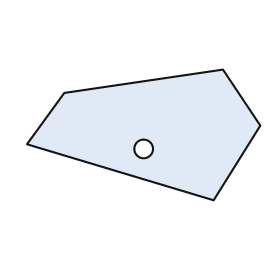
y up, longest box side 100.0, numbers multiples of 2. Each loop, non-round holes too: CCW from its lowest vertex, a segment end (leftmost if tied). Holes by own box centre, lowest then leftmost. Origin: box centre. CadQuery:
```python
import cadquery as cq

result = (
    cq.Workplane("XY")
    .moveTo(30.0, -28.0)
    .lineTo(50.0, 4.0)
    .lineTo(34.0, 28.0)
    .lineTo(-34.0, 18.0)
    .lineTo(-50.0, -4.0)
    .close()
    .moveTo(0.0, -6.0)
    .circle(4.0)
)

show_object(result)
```